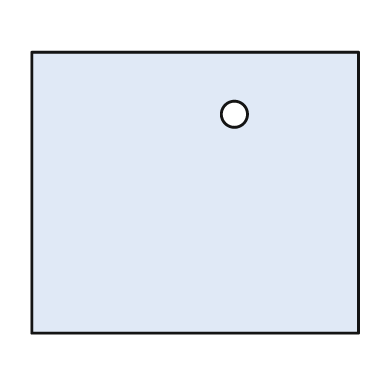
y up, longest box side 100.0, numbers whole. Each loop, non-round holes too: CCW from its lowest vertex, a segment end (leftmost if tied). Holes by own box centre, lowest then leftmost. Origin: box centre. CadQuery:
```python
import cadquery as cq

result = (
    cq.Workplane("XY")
    .moveTo(-50.0, -43.0)
    .lineTo(50.0, -43.0)
    .lineTo(50.0, 43.0)
    .lineTo(-50.0, 43.0)
    .close()
    .moveTo(12.0, 24.0)
    .circle(4.0)
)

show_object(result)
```